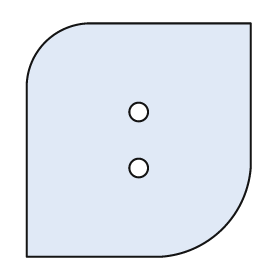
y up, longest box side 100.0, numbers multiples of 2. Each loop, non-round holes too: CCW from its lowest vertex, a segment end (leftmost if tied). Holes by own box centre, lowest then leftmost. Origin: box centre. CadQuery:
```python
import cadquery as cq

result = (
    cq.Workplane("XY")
    .moveTo(-48.0, -50.0)
    .lineTo(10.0, -50.0)
    .threePointArc((36.0, -38.0), (48.0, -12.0))
    .lineTo(48.0, 50.0)
    .lineTo(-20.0, 50.0)
    .threePointArc((-40.0, 42.0), (-48.0, 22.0))
    .close()
    .moveTo(0.0, -12.0)
    .circle(4.0)
    .moveTo(0.0, 12.0)
    .circle(4.0)
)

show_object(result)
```